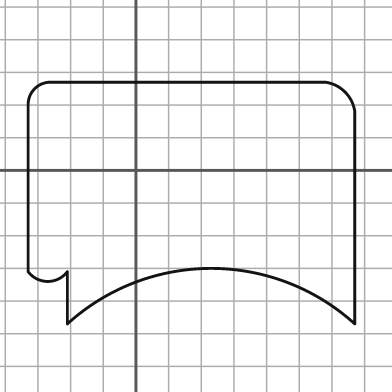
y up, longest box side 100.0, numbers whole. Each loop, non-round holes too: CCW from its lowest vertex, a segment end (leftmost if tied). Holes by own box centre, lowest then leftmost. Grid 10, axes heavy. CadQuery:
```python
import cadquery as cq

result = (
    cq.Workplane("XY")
    .moveTo(-21.0, -47.0)
    .threePointArc((23.0, -30.0), (67.0, -47.0))
    .lineTo(67.0, 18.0)
    .threePointArc((64.0, 24.0), (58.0, 27.0))
    .lineTo(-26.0, 27.0)
    .threePointArc((-31.0, 25.0), (-33.0, 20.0))
    .lineTo(-33.0, -31.0)
    .threePointArc((-27.0, -34.0), (-21.0, -31.0))
    .close()
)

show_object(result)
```